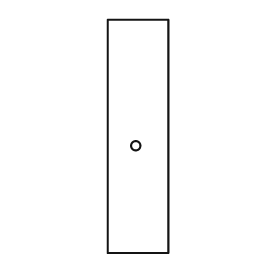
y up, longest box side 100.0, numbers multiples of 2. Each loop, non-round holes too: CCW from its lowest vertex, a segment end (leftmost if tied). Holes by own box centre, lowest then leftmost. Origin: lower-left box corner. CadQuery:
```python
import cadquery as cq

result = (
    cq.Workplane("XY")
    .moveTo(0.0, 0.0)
    .lineTo(26.0, 0.0)
    .lineTo(26.0, 100.0)
    .lineTo(0.0, 100.0)
    .close()
    .moveTo(12.0, 46.0)
    .circle(2.0)
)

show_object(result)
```